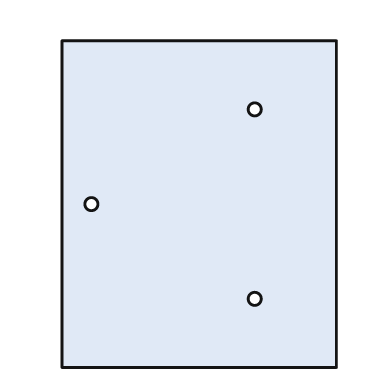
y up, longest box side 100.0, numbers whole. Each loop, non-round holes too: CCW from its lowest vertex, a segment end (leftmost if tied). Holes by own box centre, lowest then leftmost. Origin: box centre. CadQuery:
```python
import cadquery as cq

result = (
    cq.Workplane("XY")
    .moveTo(-42.0, -50.0)
    .lineTo(42.0, -50.0)
    .lineTo(42.0, 50.0)
    .lineTo(-42.0, 50.0)
    .close()
    .moveTo(17.0, -29.0)
    .circle(2.0)
    .moveTo(-33.0, 0.0)
    .circle(2.0)
    .moveTo(17.0, 29.0)
    .circle(2.0)
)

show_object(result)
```